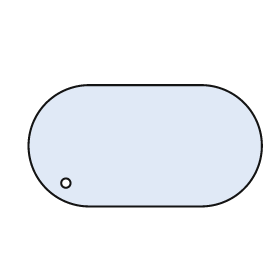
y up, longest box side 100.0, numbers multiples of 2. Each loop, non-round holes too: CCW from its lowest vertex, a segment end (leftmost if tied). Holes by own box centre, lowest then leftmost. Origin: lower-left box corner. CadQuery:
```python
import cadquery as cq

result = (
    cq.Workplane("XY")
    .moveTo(26.0, 0.0)
    .lineTo(74.0, 0.0)
    .threePointArc((100.0, 26.0), (74.0, 52.0))
    .lineTo(26.0, 52.0)
    .threePointArc((0.0, 26.0), (26.0, 0.0))
    .close()
    .moveTo(16.0, 10.0)
    .circle(2.0)
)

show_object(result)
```